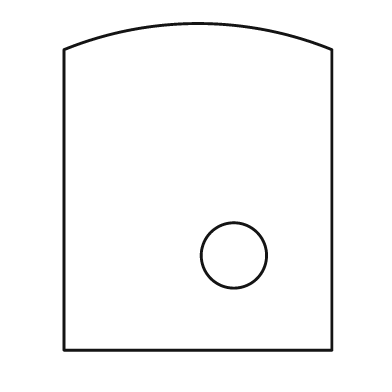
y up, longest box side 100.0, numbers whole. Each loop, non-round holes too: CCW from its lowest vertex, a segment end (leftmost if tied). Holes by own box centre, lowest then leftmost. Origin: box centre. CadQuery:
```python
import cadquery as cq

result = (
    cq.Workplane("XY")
    .moveTo(-41.0, -50.0)
    .lineTo(41.0, -50.0)
    .lineTo(41.0, 42.0)
    .threePointArc((0.0, 50.0), (-41.0, 42.0))
    .close()
    .moveTo(11.0, -21.0)
    .circle(10.0)
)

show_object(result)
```